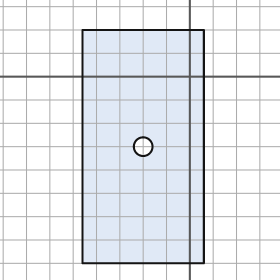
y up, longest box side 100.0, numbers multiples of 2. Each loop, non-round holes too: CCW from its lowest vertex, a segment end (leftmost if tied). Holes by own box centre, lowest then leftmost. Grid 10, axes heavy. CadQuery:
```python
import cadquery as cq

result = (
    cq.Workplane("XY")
    .moveTo(-46.0, -80.0)
    .lineTo(6.0, -80.0)
    .lineTo(6.0, 20.0)
    .lineTo(-46.0, 20.0)
    .close()
    .moveTo(-20.0, -30.0)
    .circle(4.0)
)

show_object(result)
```